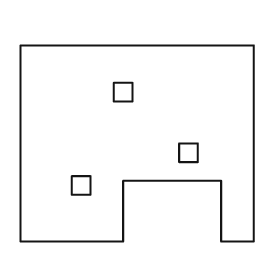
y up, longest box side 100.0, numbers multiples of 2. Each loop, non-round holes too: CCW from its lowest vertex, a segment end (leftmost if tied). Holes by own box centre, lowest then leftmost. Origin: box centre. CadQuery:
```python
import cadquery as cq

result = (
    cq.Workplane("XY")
    .moveTo(-50.0, -42.0)
    .lineTo(-6.0, -42.0)
    .lineTo(-6.0, -16.0)
    .lineTo(36.0, -16.0)
    .lineTo(36.0, -42.0)
    .lineTo(50.0, -42.0)
    .lineTo(50.0, 42.0)
    .lineTo(-50.0, 42.0)
    .close()
    .moveTo(-28.0, -22.0)
    .lineTo(-20.0, -22.0)
    .lineTo(-20.0, -14.0)
    .lineTo(-28.0, -14.0)
    .close()
    .moveTo(18.0, -8.0)
    .lineTo(26.0, -8.0)
    .lineTo(26.0, 0.0)
    .lineTo(18.0, 0.0)
    .close()
    .moveTo(-10.0, 18.0)
    .lineTo(-2.0, 18.0)
    .lineTo(-2.0, 26.0)
    .lineTo(-10.0, 26.0)
    .close()
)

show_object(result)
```